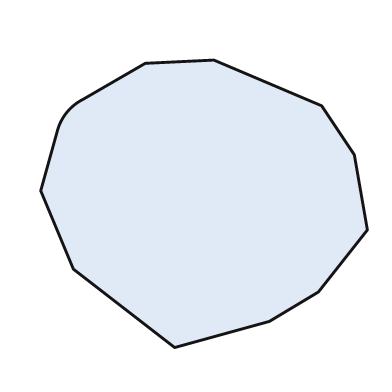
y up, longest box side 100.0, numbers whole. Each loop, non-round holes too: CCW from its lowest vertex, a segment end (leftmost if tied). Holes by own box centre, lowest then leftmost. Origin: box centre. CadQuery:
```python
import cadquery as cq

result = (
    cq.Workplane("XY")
    .moveTo(-9.0, -44.0)
    .lineTo(20.0, -36.0)
    .lineTo(35.0, -27.0)
    .lineTo(50.0, -8.0)
    .lineTo(46.0, 15.0)
    .lineTo(36.0, 30.0)
    .lineTo(3.0, 44.0)
    .lineTo(-18.0, 43.0)
    .lineTo(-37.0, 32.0)
    .threePointArc((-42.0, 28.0), (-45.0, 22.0))
    .lineTo(-50.0, 4.0)
    .lineTo(-40.0, -20.0)
    .close()
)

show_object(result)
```